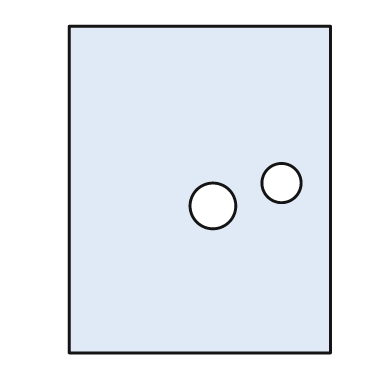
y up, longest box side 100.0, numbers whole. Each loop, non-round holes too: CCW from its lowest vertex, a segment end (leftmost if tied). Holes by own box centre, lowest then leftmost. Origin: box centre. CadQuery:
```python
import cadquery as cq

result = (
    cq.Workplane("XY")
    .moveTo(-40.0, -50.0)
    .lineTo(40.0, -50.0)
    .lineTo(40.0, 50.0)
    .lineTo(-40.0, 50.0)
    .close()
    .moveTo(4.0, -5.0)
    .circle(7.0)
    .moveTo(25.0, 2.0)
    .circle(6.0)
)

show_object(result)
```